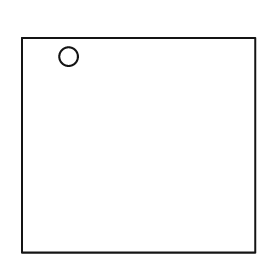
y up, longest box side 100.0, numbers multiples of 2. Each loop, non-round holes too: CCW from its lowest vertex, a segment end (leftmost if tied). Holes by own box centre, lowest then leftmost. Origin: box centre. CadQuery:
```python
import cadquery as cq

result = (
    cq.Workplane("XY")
    .moveTo(-50.0, -46.0)
    .lineTo(50.0, -46.0)
    .lineTo(50.0, 46.0)
    .lineTo(-50.0, 46.0)
    .close()
    .moveTo(-30.0, 38.0)
    .circle(4.0)
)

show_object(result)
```